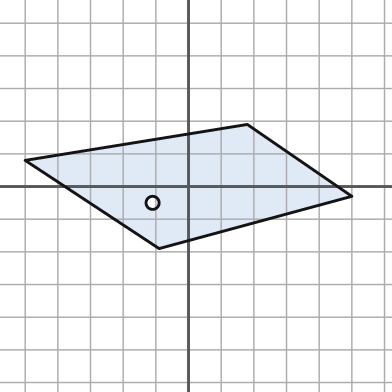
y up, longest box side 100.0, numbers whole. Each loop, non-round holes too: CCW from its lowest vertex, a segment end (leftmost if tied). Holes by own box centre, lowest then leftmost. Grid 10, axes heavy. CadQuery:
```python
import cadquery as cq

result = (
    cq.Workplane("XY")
    .moveTo(-9.0, -19.0)
    .lineTo(50.0, -3.0)
    .lineTo(18.0, 19.0)
    .lineTo(-50.0, 8.0)
    .close()
    .moveTo(-11.0, -5.0)
    .circle(2.0)
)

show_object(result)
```